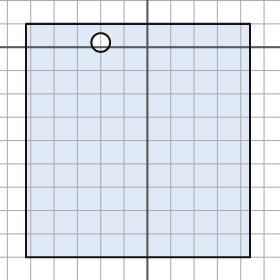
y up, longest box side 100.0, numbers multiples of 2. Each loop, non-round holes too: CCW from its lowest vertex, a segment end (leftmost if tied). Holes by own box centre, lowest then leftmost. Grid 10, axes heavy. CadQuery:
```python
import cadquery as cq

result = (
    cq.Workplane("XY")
    .moveTo(-52.0, -90.0)
    .lineTo(44.0, -90.0)
    .lineTo(44.0, 10.0)
    .lineTo(-52.0, 10.0)
    .close()
    .moveTo(-20.0, 2.0)
    .circle(4.0)
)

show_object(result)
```